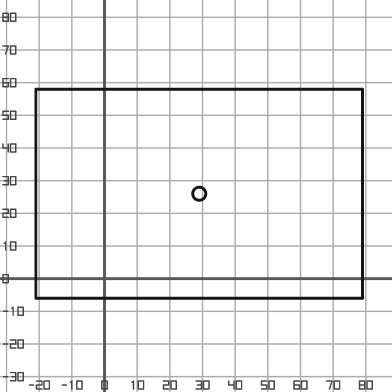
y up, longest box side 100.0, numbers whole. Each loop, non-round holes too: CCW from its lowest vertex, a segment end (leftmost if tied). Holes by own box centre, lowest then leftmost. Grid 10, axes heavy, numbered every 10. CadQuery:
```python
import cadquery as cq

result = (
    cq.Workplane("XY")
    .moveTo(-21.0, -6.0)
    .lineTo(79.0, -6.0)
    .lineTo(79.0, 58.0)
    .lineTo(-21.0, 58.0)
    .close()
    .moveTo(29.0, 26.0)
    .circle(2.0)
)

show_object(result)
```